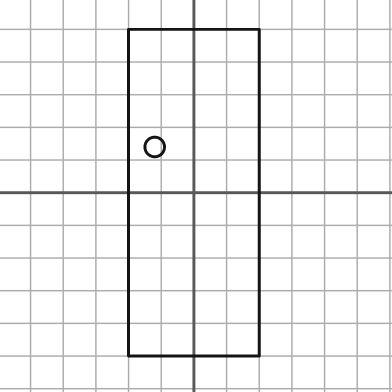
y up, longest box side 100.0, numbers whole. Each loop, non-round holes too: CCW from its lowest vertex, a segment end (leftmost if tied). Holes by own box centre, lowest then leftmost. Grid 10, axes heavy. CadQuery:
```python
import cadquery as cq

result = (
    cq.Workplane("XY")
    .moveTo(-20.0, -50.0)
    .lineTo(20.0, -50.0)
    .lineTo(20.0, 50.0)
    .lineTo(-20.0, 50.0)
    .close()
    .moveTo(-12.0, 14.0)
    .circle(3.0)
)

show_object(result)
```